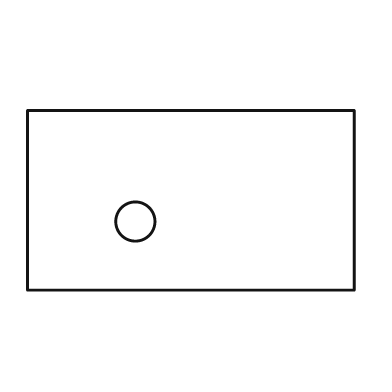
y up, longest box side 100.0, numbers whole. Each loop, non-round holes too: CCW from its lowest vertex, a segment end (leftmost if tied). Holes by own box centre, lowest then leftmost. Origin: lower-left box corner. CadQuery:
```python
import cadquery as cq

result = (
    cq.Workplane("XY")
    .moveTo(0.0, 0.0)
    .lineTo(100.0, 0.0)
    .lineTo(100.0, 55.0)
    .lineTo(0.0, 55.0)
    .close()
    .moveTo(33.0, 21.0)
    .circle(6.0)
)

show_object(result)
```